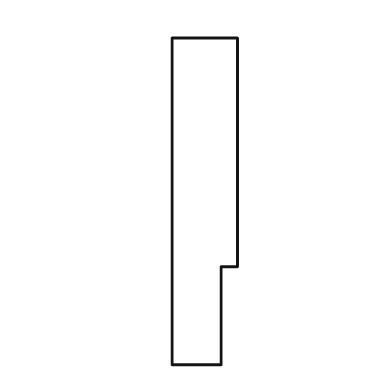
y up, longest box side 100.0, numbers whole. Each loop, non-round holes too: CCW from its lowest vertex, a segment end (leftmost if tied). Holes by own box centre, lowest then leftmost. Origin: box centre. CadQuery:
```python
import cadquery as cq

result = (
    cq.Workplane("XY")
    .moveTo(-10.0, -50.0)
    .lineTo(5.0, -50.0)
    .lineTo(5.0, -20.0)
    .lineTo(10.0, -20.0)
    .lineTo(10.0, 50.0)
    .lineTo(-10.0, 50.0)
    .close()
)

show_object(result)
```